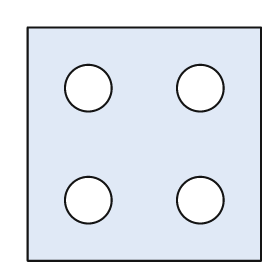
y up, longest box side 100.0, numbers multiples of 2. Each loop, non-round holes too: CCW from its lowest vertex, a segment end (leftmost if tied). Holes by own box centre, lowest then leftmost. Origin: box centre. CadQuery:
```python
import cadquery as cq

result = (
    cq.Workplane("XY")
    .moveTo(-50.0, -50.0)
    .lineTo(50.0, -50.0)
    .lineTo(50.0, 50.0)
    .lineTo(-50.0, 50.0)
    .close()
    .moveTo(-24.0, -24.0)
    .circle(10.0)
    .moveTo(24.0, -24.0)
    .circle(10.0)
    .moveTo(-24.0, 24.0)
    .circle(10.0)
    .moveTo(24.0, 24.0)
    .circle(10.0)
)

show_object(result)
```